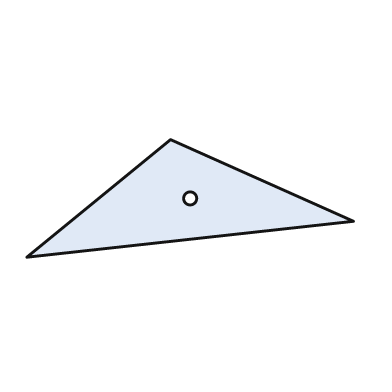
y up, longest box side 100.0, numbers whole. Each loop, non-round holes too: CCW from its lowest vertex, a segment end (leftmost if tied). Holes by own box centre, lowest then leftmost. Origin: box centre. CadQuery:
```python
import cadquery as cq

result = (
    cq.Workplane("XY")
    .moveTo(-50.0, -18.0)
    .lineTo(50.0, -7.0)
    .lineTo(-6.0, 18.0)
    .close()
    .moveTo(0.0, 0.0)
    .circle(2.0)
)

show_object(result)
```